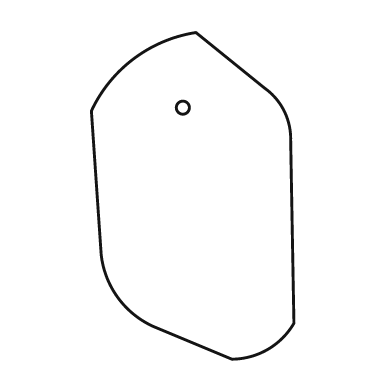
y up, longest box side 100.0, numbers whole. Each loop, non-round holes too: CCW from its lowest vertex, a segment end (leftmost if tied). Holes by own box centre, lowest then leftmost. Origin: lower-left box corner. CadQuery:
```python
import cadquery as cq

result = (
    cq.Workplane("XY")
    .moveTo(43.0, 0.0)
    .threePointArc((54.0, 3.0), (62.0, 11.0))
    .lineTo(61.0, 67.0)
    .threePointArc((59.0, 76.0), (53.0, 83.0))
    .lineTo(32.0, 100.0)
    .threePointArc((13.0, 92.0), (0.0, 76.0))
    .lineTo(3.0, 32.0)
    .threePointArc((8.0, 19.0), (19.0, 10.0))
    .close()
    .moveTo(28.0, 77.0)
    .circle(2.0)
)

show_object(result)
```